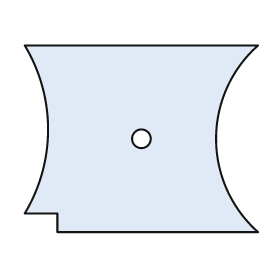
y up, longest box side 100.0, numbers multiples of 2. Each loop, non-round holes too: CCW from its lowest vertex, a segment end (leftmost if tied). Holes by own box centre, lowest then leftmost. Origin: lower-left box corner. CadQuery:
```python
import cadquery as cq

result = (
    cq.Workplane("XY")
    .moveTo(14.0, 0.0)
    .lineTo(100.0, 0.0)
    .threePointArc((82.0, 40.0), (100.0, 80.0))
    .lineTo(0.0, 80.0)
    .threePointArc((10.0, 44.0), (0.0, 8.0))
    .lineTo(14.0, 8.0)
    .close()
    .moveTo(50.0, 40.0)
    .circle(4.0)
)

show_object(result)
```